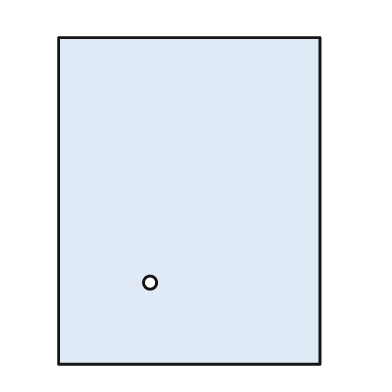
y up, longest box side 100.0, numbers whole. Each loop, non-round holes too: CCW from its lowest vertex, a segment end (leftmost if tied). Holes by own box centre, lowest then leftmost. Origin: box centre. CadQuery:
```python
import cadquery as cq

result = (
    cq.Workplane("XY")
    .moveTo(-40.0, -50.0)
    .lineTo(40.0, -50.0)
    .lineTo(40.0, 50.0)
    .lineTo(-40.0, 50.0)
    .close()
    .moveTo(-12.0, -25.0)
    .circle(2.0)
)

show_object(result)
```